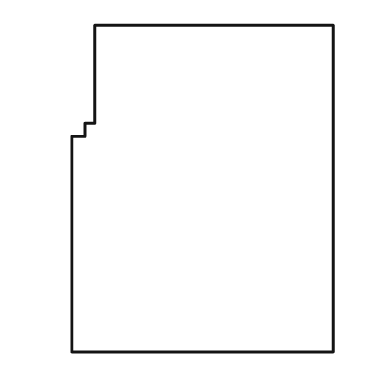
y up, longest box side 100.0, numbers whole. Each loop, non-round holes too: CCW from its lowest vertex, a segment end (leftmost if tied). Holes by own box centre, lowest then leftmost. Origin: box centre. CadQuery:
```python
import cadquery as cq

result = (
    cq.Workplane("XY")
    .moveTo(-40.0, -50.0)
    .lineTo(40.0, -50.0)
    .lineTo(40.0, 50.0)
    .lineTo(-33.0, 50.0)
    .lineTo(-33.0, 20.0)
    .lineTo(-36.0, 20.0)
    .lineTo(-36.0, 16.0)
    .lineTo(-40.0, 16.0)
    .close()
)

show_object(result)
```